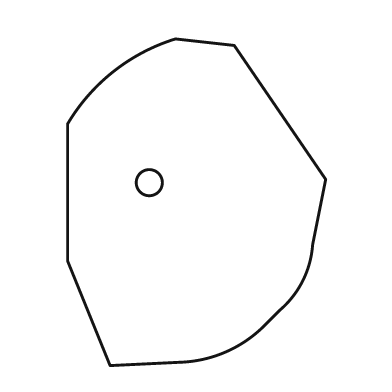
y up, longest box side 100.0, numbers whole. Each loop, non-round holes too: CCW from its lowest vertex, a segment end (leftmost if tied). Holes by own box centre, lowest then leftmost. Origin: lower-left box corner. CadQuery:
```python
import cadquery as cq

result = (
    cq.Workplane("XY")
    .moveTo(13.0, 0.0)
    .lineTo(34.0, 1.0)
    .threePointArc((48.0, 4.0), (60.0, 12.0))
    .lineTo(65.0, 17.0)
    .threePointArc((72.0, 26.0), (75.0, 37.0))
    .lineTo(79.0, 57.0)
    .lineTo(51.0, 98.0)
    .lineTo(33.0, 100.0)
    .threePointArc((14.0, 90.0), (0.0, 74.0))
    .lineTo(0.0, 32.0)
    .close()
    .moveTo(25.0, 56.0)
    .circle(4.0)
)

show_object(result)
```